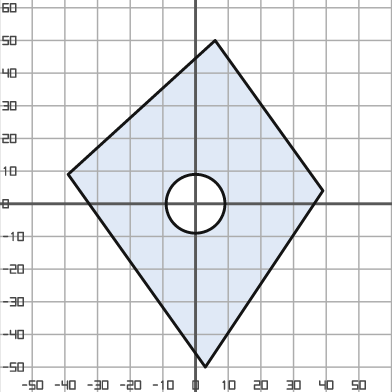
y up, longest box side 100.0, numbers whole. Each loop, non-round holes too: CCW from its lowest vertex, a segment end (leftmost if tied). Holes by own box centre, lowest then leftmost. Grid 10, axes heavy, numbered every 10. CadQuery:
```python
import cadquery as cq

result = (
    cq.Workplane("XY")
    .moveTo(3.0, -50.0)
    .lineTo(39.0, 4.0)
    .lineTo(6.0, 50.0)
    .lineTo(-39.0, 9.0)
    .close()
    .moveTo(0.0, 0.0)
    .circle(9.0)
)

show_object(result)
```